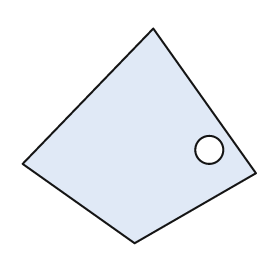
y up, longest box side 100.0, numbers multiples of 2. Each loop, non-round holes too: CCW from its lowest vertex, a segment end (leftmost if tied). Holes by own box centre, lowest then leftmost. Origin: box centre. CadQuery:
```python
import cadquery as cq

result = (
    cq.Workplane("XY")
    .moveTo(-2.0, -46.0)
    .lineTo(50.0, -16.0)
    .lineTo(6.0, 46.0)
    .lineTo(-50.0, -12.0)
    .close()
    .moveTo(30.0, -6.0)
    .circle(6.0)
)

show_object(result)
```